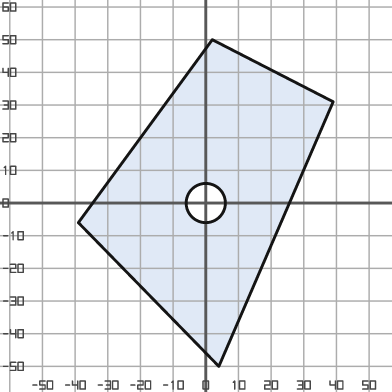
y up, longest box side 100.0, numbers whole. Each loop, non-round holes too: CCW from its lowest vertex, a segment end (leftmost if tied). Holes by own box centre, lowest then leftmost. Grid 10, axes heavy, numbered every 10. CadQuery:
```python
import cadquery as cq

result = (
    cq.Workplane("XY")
    .moveTo(4.0, -50.0)
    .lineTo(39.0, 31.0)
    .lineTo(2.0, 50.0)
    .lineTo(-39.0, -6.0)
    .close()
    .moveTo(0.0, 0.0)
    .circle(6.0)
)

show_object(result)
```